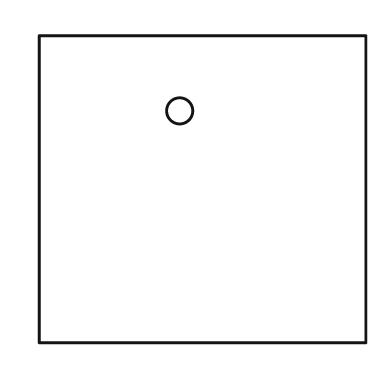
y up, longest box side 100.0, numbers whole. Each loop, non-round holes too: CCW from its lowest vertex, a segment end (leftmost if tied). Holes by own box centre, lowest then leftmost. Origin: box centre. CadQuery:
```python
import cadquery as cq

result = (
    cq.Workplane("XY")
    .moveTo(-50.0, -47.0)
    .lineTo(50.0, -47.0)
    .lineTo(50.0, 47.0)
    .lineTo(-50.0, 47.0)
    .close()
    .moveTo(-7.0, 24.0)
    .circle(4.0)
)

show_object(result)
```